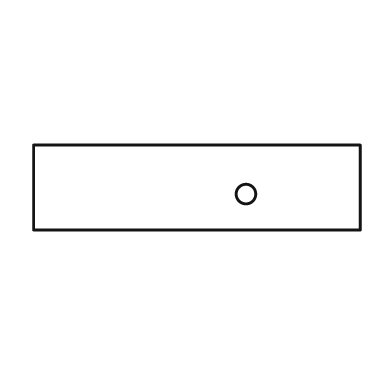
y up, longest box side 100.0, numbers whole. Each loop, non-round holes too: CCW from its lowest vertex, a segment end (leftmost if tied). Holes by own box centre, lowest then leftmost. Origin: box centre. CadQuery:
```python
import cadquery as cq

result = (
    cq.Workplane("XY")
    .moveTo(-50.0, -13.0)
    .lineTo(50.0, -13.0)
    .lineTo(50.0, 13.0)
    .lineTo(-50.0, 13.0)
    .close()
    .moveTo(15.0, -2.0)
    .circle(3.0)
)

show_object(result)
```